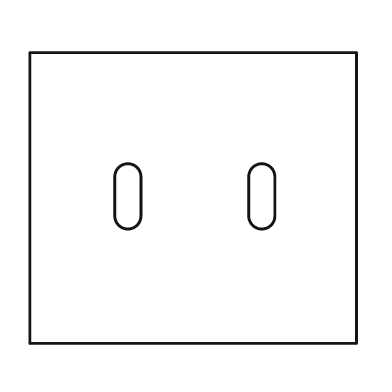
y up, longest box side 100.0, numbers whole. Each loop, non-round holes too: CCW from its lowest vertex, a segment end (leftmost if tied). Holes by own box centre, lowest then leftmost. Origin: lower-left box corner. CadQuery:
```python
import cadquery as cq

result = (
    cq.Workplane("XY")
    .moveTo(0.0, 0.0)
    .lineTo(100.0, 0.0)
    .lineTo(100.0, 89.0)
    .lineTo(0.0, 89.0)
    .close()
    .moveTo(26.0, 39.0)
    .threePointArc((30.0, 35.0), (34.0, 39.0))
    .lineTo(34.0, 51.0)
    .threePointArc((30.0, 55.0), (26.0, 51.0))
    .close()
    .moveTo(67.0, 39.0)
    .threePointArc((71.0, 35.0), (75.0, 39.0))
    .lineTo(75.0, 51.0)
    .threePointArc((71.0, 55.0), (67.0, 51.0))
    .close()
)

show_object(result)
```